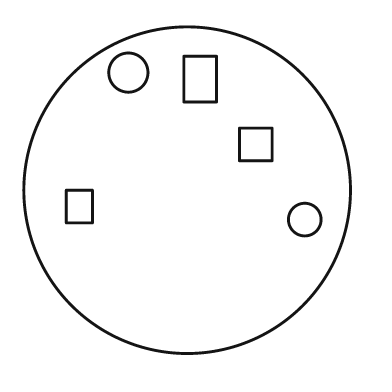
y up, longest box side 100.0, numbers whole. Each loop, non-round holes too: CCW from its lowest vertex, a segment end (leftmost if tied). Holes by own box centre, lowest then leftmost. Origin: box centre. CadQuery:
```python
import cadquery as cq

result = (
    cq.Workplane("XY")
    .moveTo(0.0, 0.0)
    .circle(50.0)
    .moveTo(36.0, -9.0)
    .circle(5.0)
    .moveTo(-37.0, -10.0)
    .lineTo(-29.0, -10.0)
    .lineTo(-29.0, 0.0)
    .lineTo(-37.0, 0.0)
    .close()
    .moveTo(16.0, 9.0)
    .lineTo(26.0, 9.0)
    .lineTo(26.0, 19.0)
    .lineTo(16.0, 19.0)
    .close()
    .moveTo(-1.0, 27.0)
    .lineTo(9.0, 27.0)
    .lineTo(9.0, 41.0)
    .lineTo(-1.0, 41.0)
    .close()
    .moveTo(-18.0, 36.0)
    .circle(6.0)
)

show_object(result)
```